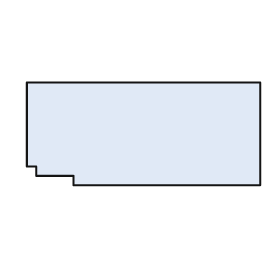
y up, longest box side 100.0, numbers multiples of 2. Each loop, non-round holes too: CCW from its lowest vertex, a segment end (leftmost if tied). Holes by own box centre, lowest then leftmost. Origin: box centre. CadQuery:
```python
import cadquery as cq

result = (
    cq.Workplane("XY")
    .moveTo(-30.0, -22.0)
    .lineTo(50.0, -22.0)
    .lineTo(50.0, 22.0)
    .lineTo(-50.0, 22.0)
    .lineTo(-50.0, -14.0)
    .lineTo(-46.0, -14.0)
    .lineTo(-46.0, -18.0)
    .lineTo(-30.0, -18.0)
    .close()
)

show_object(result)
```